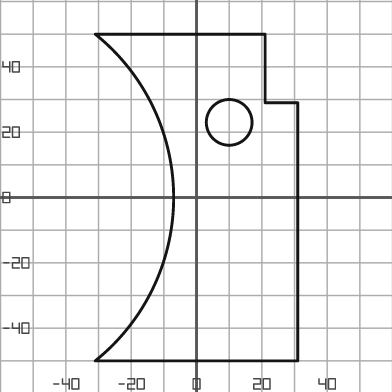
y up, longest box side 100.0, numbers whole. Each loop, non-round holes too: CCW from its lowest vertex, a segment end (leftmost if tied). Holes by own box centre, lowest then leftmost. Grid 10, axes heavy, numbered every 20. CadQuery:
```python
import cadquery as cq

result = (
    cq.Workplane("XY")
    .moveTo(-31.0, -50.0)
    .lineTo(31.0, -50.0)
    .lineTo(31.0, 29.0)
    .lineTo(21.0, 29.0)
    .lineTo(21.0, 50.0)
    .lineTo(-31.0, 50.0)
    .threePointArc((-7.0, 0.0), (-31.0, -50.0))
    .close()
    .moveTo(10.0, 23.0)
    .circle(7.0)
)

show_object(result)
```